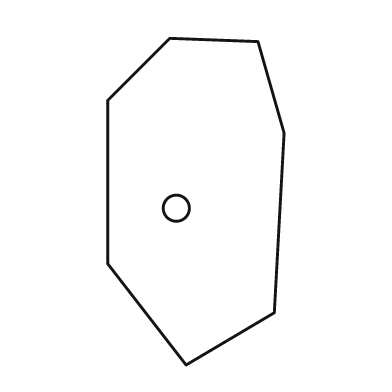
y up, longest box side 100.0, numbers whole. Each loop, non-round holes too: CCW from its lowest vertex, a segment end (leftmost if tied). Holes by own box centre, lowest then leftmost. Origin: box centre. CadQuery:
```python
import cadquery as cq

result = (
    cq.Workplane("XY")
    .moveTo(-3.0, -50.0)
    .lineTo(24.0, -34.0)
    .lineTo(27.0, 21.0)
    .lineTo(19.0, 49.0)
    .lineTo(-8.0, 50.0)
    .lineTo(-27.0, 31.0)
    .lineTo(-27.0, -19.0)
    .close()
    .moveTo(-6.0, -2.0)
    .circle(4.0)
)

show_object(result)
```